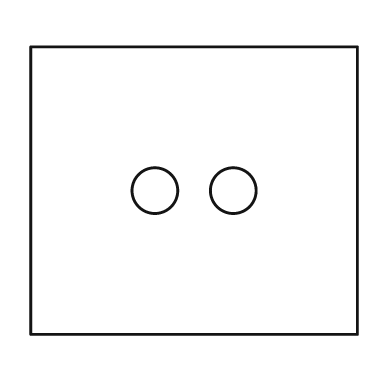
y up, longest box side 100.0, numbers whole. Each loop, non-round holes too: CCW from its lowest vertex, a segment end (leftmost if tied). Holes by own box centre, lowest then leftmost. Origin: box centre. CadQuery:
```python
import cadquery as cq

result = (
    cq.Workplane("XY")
    .moveTo(-50.0, -44.0)
    .lineTo(50.0, -44.0)
    .lineTo(50.0, 44.0)
    .lineTo(-50.0, 44.0)
    .close()
    .moveTo(-12.0, 0.0)
    .circle(7.0)
    .moveTo(12.0, 0.0)
    .circle(7.0)
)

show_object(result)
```